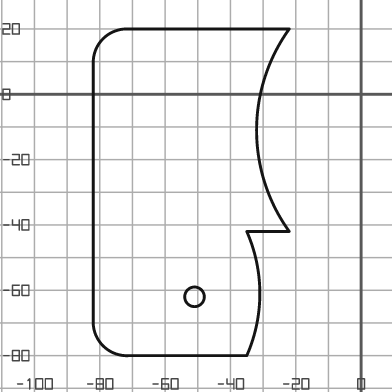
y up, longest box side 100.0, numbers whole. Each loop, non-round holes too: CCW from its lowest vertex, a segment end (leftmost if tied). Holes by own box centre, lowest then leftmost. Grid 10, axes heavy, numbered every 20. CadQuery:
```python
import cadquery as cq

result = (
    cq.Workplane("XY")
    .moveTo(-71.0, -80.0)
    .lineTo(-35.0, -80.0)
    .threePointArc((-31.0, -61.0), (-35.0, -42.0))
    .lineTo(-22.0, -42.0)
    .threePointArc((-32.0, -11.0), (-22.0, 20.0))
    .lineTo(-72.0, 20.0)
    .threePointArc((-79.0, 17.0), (-82.0, 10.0))
    .lineTo(-82.0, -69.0)
    .threePointArc((-79.0, -77.0), (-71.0, -80.0))
    .close()
    .moveTo(-51.0, -62.0)
    .circle(3.0)
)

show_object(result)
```